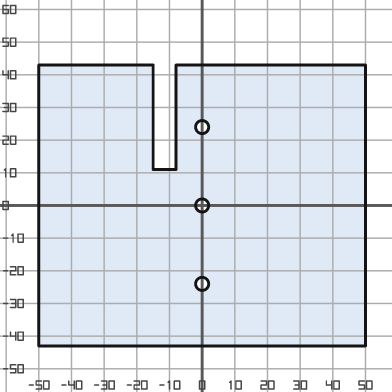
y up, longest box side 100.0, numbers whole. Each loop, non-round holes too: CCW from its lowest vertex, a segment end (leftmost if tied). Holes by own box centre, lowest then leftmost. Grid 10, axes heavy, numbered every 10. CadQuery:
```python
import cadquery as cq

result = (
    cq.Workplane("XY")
    .moveTo(-50.0, -43.0)
    .lineTo(50.0, -43.0)
    .lineTo(50.0, 43.0)
    .lineTo(-8.0, 43.0)
    .lineTo(-8.0, 11.0)
    .lineTo(-15.0, 11.0)
    .lineTo(-15.0, 43.0)
    .lineTo(-50.0, 43.0)
    .close()
    .moveTo(0.0, -24.0)
    .circle(2.0)
    .moveTo(0.0, 0.0)
    .circle(2.0)
    .moveTo(0.0, 24.0)
    .circle(2.0)
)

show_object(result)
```